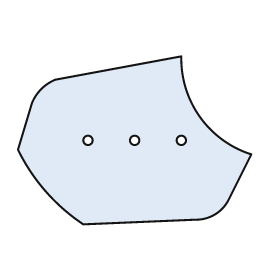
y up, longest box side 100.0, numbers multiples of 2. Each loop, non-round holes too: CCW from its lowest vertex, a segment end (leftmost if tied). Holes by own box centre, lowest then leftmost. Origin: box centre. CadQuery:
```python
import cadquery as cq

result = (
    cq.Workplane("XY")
    .moveTo(-22.0, -36.0)
    .lineTo(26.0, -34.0)
    .threePointArc((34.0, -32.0), (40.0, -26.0))
    .lineTo(50.0, -6.0)
    .threePointArc((28.0, 10.0), (20.0, 36.0))
    .lineTo(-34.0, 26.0)
    .threePointArc((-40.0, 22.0), (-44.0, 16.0))
    .lineTo(-50.0, -4.0)
    .threePointArc((-38.0, -22.0), (-22.0, -36.0))
    .close()
    .moveTo(-20.0, 0.0)
    .circle(2.0)
    .moveTo(0.0, 0.0)
    .circle(2.0)
    .moveTo(20.0, 0.0)
    .circle(2.0)
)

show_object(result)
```